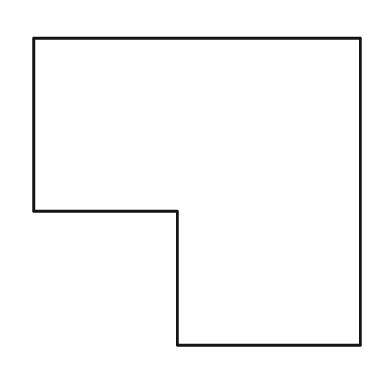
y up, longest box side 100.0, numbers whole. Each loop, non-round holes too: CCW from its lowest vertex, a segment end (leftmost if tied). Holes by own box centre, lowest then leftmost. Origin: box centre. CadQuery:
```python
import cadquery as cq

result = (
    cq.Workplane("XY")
    .moveTo(-6.0, -47.0)
    .lineTo(50.0, -47.0)
    .lineTo(50.0, 47.0)
    .lineTo(-50.0, 47.0)
    .lineTo(-50.0, -6.0)
    .lineTo(-6.0, -6.0)
    .close()
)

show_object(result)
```